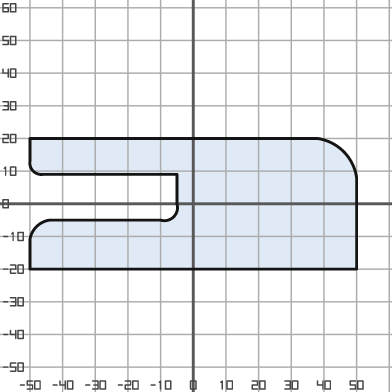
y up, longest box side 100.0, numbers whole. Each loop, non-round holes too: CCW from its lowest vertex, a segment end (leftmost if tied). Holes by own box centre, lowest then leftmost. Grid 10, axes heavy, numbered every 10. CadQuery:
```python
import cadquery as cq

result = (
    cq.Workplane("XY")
    .moveTo(-50.0, -20.0)
    .lineTo(50.0, -20.0)
    .lineTo(50.0, 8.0)
    .threePointArc((46.0, 16.0), (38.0, 20.0))
    .lineTo(-50.0, 20.0)
    .lineTo(-50.0, 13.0)
    .threePointArc((-49.0, 10.0), (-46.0, 9.0))
    .lineTo(-5.0, 9.0)
    .lineTo(-5.0, 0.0)
    .threePointArc((-6.0, -4.0), (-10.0, -5.0))
    .lineTo(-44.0, -5.0)
    .threePointArc((-48.0, -7.0), (-50.0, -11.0))
    .close()
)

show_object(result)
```